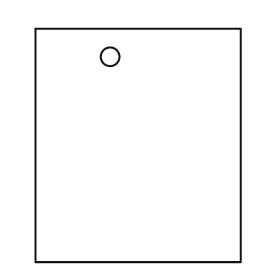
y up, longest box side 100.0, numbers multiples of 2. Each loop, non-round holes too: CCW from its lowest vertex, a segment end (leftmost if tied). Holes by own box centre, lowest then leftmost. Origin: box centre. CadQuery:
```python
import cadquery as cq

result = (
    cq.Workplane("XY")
    .moveTo(-44.0, -50.0)
    .lineTo(44.0, -50.0)
    .lineTo(44.0, 50.0)
    .lineTo(-44.0, 50.0)
    .close()
    .moveTo(-12.0, 38.0)
    .circle(4.0)
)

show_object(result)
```